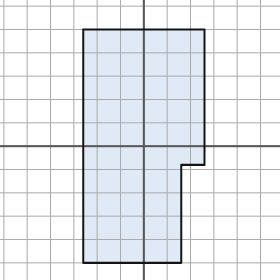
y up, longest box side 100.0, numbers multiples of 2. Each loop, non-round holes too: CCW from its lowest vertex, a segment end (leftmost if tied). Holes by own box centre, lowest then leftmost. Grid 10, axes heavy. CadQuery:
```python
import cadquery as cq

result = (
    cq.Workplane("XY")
    .moveTo(-26.0, -50.0)
    .lineTo(16.0, -50.0)
    .lineTo(16.0, -8.0)
    .lineTo(26.0, -8.0)
    .lineTo(26.0, 50.0)
    .lineTo(-26.0, 50.0)
    .close()
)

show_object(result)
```